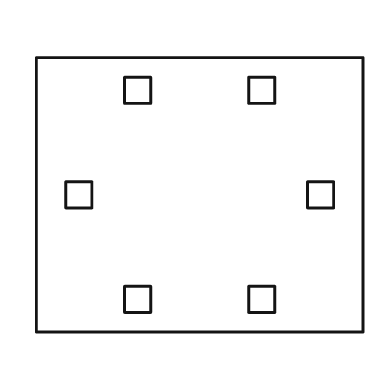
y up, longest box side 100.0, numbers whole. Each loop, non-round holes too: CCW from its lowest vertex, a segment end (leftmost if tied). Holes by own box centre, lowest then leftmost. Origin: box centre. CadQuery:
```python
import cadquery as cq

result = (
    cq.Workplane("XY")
    .moveTo(-50.0, -42.0)
    .lineTo(50.0, -42.0)
    .lineTo(50.0, 42.0)
    .lineTo(-50.0, 42.0)
    .close()
    .moveTo(-23.0, -36.0)
    .lineTo(-15.0, -36.0)
    .lineTo(-15.0, -28.0)
    .lineTo(-23.0, -28.0)
    .close()
    .moveTo(15.0, -36.0)
    .lineTo(23.0, -36.0)
    .lineTo(23.0, -28.0)
    .lineTo(15.0, -28.0)
    .close()
    .moveTo(-41.0, -4.0)
    .lineTo(-33.0, -4.0)
    .lineTo(-33.0, 4.0)
    .lineTo(-41.0, 4.0)
    .close()
    .moveTo(33.0, -4.0)
    .lineTo(41.0, -4.0)
    .lineTo(41.0, 4.0)
    .lineTo(33.0, 4.0)
    .close()
    .moveTo(-23.0, 28.0)
    .lineTo(-15.0, 28.0)
    .lineTo(-15.0, 36.0)
    .lineTo(-23.0, 36.0)
    .close()
    .moveTo(15.0, 28.0)
    .lineTo(23.0, 28.0)
    .lineTo(23.0, 36.0)
    .lineTo(15.0, 36.0)
    .close()
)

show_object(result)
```